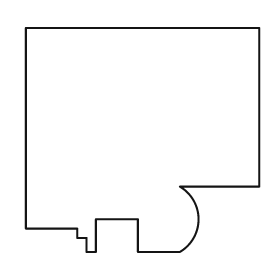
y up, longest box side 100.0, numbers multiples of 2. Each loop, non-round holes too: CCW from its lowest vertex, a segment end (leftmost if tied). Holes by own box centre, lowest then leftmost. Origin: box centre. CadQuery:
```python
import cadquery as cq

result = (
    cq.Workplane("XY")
    .moveTo(-24.0, -48.0)
    .lineTo(-20.0, -48.0)
    .lineTo(-20.0, -34.0)
    .lineTo(-2.0, -34.0)
    .lineTo(-2.0, -48.0)
    .lineTo(16.0, -48.0)
    .threePointArc((24.0, -34.0), (16.0, -20.0))
    .lineTo(50.0, -20.0)
    .lineTo(50.0, 48.0)
    .lineTo(-50.0, 48.0)
    .lineTo(-50.0, -38.0)
    .lineTo(-28.0, -38.0)
    .lineTo(-28.0, -42.0)
    .lineTo(-24.0, -42.0)
    .close()
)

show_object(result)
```